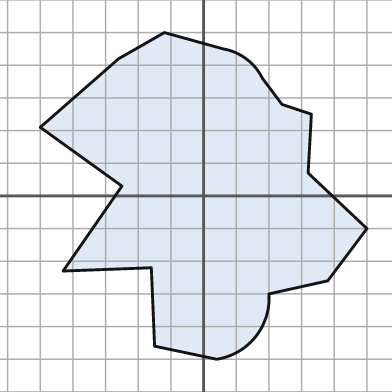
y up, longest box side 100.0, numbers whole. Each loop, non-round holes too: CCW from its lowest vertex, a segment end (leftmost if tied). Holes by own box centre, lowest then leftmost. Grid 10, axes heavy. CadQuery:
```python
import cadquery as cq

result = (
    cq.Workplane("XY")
    .moveTo(4.0, -50.0)
    .threePointArc((16.0, -43.0), (20.0, -30.0))
    .lineTo(38.0, -26.0)
    .lineTo(50.0, -10.0)
    .lineTo(32.0, 7.0)
    .lineTo(33.0, 25.0)
    .lineTo(24.0, 28.0)
    .lineTo(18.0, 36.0)
    .threePointArc((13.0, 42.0), (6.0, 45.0))
    .lineTo(-12.0, 50.0)
    .lineTo(-26.0, 42.0)
    .lineTo(-50.0, 21.0)
    .lineTo(-25.0, 3.0)
    .lineTo(-43.0, -23.0)
    .lineTo(-16.0, -22.0)
    .lineTo(-15.0, -46.0)
    .close()
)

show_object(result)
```